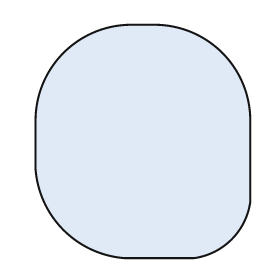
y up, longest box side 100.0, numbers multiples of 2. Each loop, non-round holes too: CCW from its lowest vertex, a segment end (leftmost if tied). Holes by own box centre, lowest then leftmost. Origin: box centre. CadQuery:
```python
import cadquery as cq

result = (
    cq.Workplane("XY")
    .moveTo(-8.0, -50.0)
    .lineTo(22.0, -50.0)
    .threePointArc((38.0, -42.0), (46.0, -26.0))
    .lineTo(46.0, 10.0)
    .threePointArc((34.0, 38.0), (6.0, 50.0))
    .lineTo(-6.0, 50.0)
    .threePointArc((-34.0, 38.0), (-46.0, 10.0))
    .lineTo(-46.0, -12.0)
    .threePointArc((-34.0, -38.0), (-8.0, -50.0))
    .close()
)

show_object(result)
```